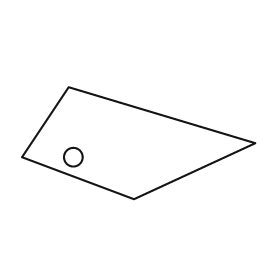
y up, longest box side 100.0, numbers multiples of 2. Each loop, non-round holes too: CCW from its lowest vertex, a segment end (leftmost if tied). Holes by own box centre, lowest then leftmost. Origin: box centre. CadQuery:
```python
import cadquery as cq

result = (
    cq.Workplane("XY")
    .moveTo(-2.0, -24.0)
    .lineTo(50.0, 0.0)
    .lineTo(-30.0, 24.0)
    .lineTo(-50.0, -6.0)
    .close()
    .moveTo(-28.0, -6.0)
    .circle(4.0)
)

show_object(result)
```